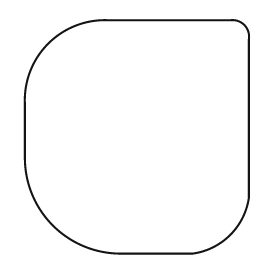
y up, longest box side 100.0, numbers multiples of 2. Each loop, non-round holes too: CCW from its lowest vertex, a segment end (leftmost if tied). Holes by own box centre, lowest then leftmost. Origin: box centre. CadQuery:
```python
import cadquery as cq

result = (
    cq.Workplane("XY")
    .moveTo(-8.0, -50.0)
    .lineTo(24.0, -50.0)
    .threePointArc((40.0, -42.0), (48.0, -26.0))
    .lineTo(48.0, 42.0)
    .threePointArc((46.0, 48.0), (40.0, 50.0))
    .lineTo(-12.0, 50.0)
    .threePointArc((-38.0, 40.0), (-48.0, 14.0))
    .lineTo(-48.0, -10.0)
    .threePointArc((-36.0, -38.0), (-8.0, -50.0))
    .close()
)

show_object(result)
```